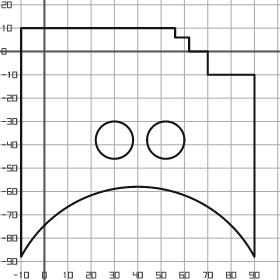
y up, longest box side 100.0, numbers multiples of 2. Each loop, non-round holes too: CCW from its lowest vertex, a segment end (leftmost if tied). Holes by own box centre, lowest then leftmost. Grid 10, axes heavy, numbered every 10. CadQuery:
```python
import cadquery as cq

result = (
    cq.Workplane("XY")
    .moveTo(-10.0, -88.0)
    .threePointArc((40.0, -58.0), (90.0, -88.0))
    .lineTo(90.0, -10.0)
    .lineTo(70.0, -10.0)
    .lineTo(70.0, 0.0)
    .lineTo(62.0, 0.0)
    .lineTo(62.0, 6.0)
    .lineTo(56.0, 6.0)
    .lineTo(56.0, 10.0)
    .lineTo(-10.0, 10.0)
    .close()
    .moveTo(30.0, -38.0)
    .circle(8.0)
    .moveTo(52.0, -38.0)
    .circle(8.0)
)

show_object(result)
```